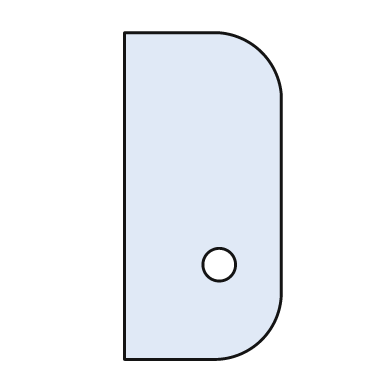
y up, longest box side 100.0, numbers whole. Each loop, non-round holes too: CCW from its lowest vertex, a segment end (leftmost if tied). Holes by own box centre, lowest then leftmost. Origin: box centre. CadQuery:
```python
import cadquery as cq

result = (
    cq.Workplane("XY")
    .moveTo(-24.0, -50.0)
    .lineTo(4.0, -50.0)
    .threePointArc((18.0, -44.0), (24.0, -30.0))
    .lineTo(24.0, 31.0)
    .threePointArc((18.0, 44.0), (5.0, 50.0))
    .lineTo(-24.0, 50.0)
    .close()
    .moveTo(5.0, -21.0)
    .circle(5.0)
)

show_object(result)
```